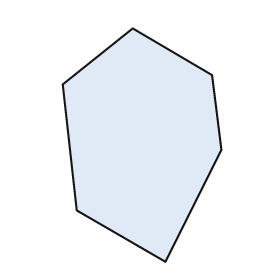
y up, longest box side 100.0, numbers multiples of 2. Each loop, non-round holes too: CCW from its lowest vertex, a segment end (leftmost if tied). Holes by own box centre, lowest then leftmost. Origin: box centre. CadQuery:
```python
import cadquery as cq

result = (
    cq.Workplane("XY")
    .moveTo(10.0, -50.0)
    .lineTo(34.0, -2.0)
    .lineTo(30.0, 30.0)
    .lineTo(-4.0, 50.0)
    .lineTo(-34.0, 26.0)
    .lineTo(-28.0, -28.0)
    .close()
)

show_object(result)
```